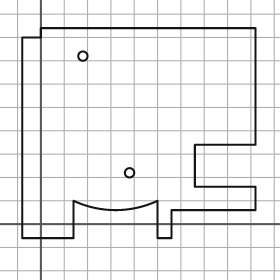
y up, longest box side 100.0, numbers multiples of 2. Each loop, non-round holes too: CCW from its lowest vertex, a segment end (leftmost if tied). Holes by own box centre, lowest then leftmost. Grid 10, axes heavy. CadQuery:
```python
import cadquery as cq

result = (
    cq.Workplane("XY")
    .moveTo(-8.0, -6.0)
    .lineTo(14.0, -6.0)
    .lineTo(14.0, 10.0)
    .threePointArc((32.0, 6.0), (50.0, 10.0))
    .lineTo(50.0, -6.0)
    .lineTo(56.0, -6.0)
    .lineTo(56.0, 6.0)
    .lineTo(92.0, 6.0)
    .lineTo(92.0, 16.0)
    .lineTo(66.0, 16.0)
    .lineTo(66.0, 34.0)
    .lineTo(92.0, 34.0)
    .lineTo(92.0, 84.0)
    .lineTo(0.0, 84.0)
    .lineTo(0.0, 80.0)
    .lineTo(-8.0, 80.0)
    .close()
    .moveTo(38.0, 22.0)
    .circle(2.0)
    .moveTo(18.0, 72.0)
    .circle(2.0)
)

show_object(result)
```